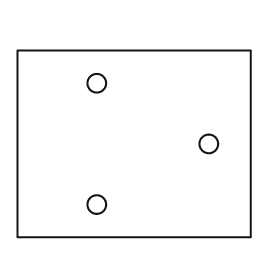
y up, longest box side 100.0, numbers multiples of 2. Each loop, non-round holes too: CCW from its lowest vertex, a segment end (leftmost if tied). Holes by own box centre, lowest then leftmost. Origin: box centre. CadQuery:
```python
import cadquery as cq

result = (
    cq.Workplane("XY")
    .moveTo(-50.0, -40.0)
    .lineTo(50.0, -40.0)
    .lineTo(50.0, 40.0)
    .lineTo(-50.0, 40.0)
    .close()
    .moveTo(-16.0, -26.0)
    .circle(4.0)
    .moveTo(32.0, 0.0)
    .circle(4.0)
    .moveTo(-16.0, 26.0)
    .circle(4.0)
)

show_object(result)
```